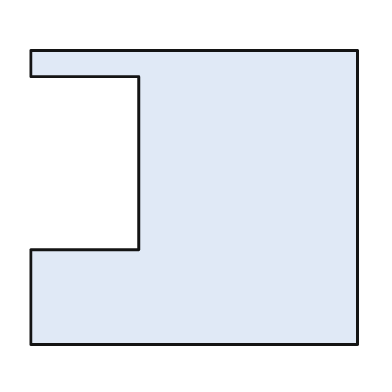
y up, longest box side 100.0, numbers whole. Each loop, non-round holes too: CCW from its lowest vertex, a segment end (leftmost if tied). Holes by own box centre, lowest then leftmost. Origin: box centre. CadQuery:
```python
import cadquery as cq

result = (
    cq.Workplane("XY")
    .moveTo(-50.0, -45.0)
    .lineTo(50.0, -45.0)
    .lineTo(50.0, 45.0)
    .lineTo(-50.0, 45.0)
    .lineTo(-50.0, 37.0)
    .lineTo(-17.0, 37.0)
    .lineTo(-17.0, -16.0)
    .lineTo(-50.0, -16.0)
    .close()
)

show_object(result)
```